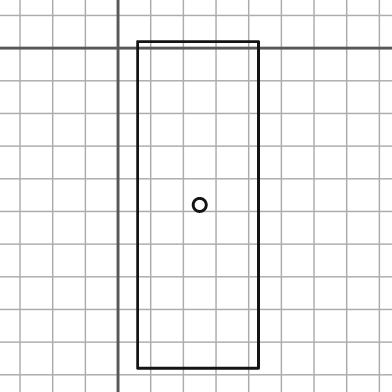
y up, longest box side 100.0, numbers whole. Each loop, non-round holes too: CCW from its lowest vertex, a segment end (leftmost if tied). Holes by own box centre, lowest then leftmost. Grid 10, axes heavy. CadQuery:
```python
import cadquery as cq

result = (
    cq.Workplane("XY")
    .moveTo(6.0, -98.0)
    .lineTo(43.0, -98.0)
    .lineTo(43.0, 2.0)
    .lineTo(6.0, 2.0)
    .close()
    .moveTo(25.0, -48.0)
    .circle(2.0)
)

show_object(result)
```